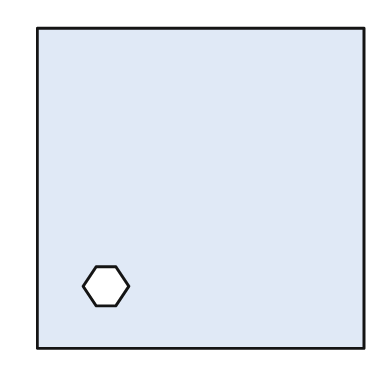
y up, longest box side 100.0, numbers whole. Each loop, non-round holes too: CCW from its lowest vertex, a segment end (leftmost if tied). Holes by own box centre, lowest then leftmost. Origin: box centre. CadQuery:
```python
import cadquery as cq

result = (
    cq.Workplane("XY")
    .moveTo(-50.0, -49.0)
    .lineTo(50.0, -49.0)
    .lineTo(50.0, 49.0)
    .lineTo(-50.0, 49.0)
    .close()
    .moveTo(-32.0, -36.0)
    .lineTo(-26.0, -36.0)
    .lineTo(-22.0, -30.0)
    .lineTo(-26.0, -24.0)
    .lineTo(-32.0, -24.0)
    .lineTo(-36.0, -30.0)
    .close()
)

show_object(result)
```